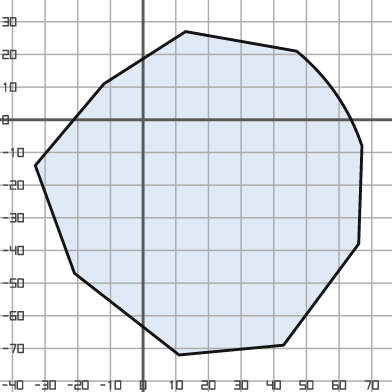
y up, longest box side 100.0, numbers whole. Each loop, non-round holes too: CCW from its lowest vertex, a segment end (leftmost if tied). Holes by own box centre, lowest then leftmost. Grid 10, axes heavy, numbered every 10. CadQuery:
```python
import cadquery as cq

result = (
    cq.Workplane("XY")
    .moveTo(11.0, -72.0)
    .lineTo(43.0, -69.0)
    .lineTo(66.0, -38.0)
    .lineTo(67.0, -8.0)
    .threePointArc((59.0, 8.0), (47.0, 21.0))
    .lineTo(13.0, 27.0)
    .lineTo(-12.0, 11.0)
    .lineTo(-33.0, -14.0)
    .lineTo(-21.0, -47.0)
    .close()
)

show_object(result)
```